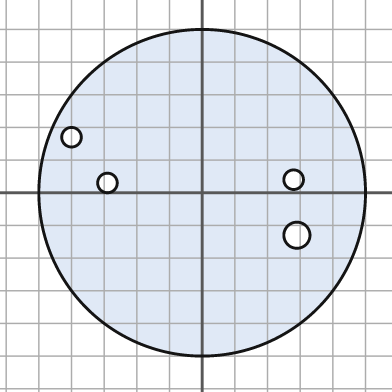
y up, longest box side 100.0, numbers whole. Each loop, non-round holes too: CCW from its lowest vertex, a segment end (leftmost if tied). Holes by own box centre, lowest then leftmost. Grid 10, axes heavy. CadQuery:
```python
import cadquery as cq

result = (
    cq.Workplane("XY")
    .moveTo(0.0, 0.0)
    .circle(50.0)
    .moveTo(29.0, -13.0)
    .circle(4.0)
    .moveTo(-29.0, 3.0)
    .circle(3.0)
    .moveTo(28.0, 4.0)
    .circle(3.0)
    .moveTo(-40.0, 17.0)
    .circle(3.0)
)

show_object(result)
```